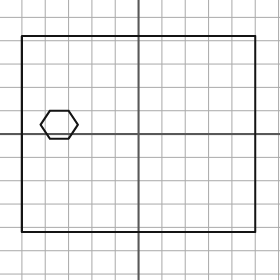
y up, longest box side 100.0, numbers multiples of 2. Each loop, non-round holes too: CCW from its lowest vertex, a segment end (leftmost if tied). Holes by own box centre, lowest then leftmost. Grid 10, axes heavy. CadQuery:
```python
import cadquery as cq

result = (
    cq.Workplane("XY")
    .moveTo(-50.0, -42.0)
    .lineTo(50.0, -42.0)
    .lineTo(50.0, 42.0)
    .lineTo(-50.0, 42.0)
    .close()
    .moveTo(-38.0, -2.0)
    .lineTo(-30.0, -2.0)
    .lineTo(-26.0, 4.0)
    .lineTo(-30.0, 10.0)
    .lineTo(-38.0, 10.0)
    .lineTo(-42.0, 4.0)
    .close()
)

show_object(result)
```